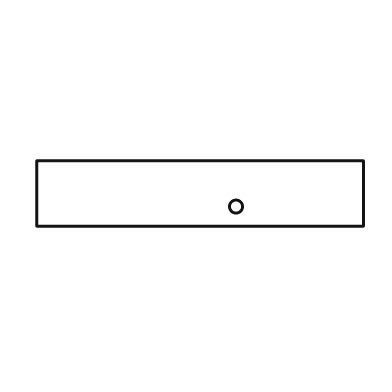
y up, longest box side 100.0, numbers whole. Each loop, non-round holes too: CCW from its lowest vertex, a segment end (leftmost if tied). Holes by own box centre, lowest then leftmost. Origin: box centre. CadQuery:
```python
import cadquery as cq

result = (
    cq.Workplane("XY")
    .moveTo(-50.0, -10.0)
    .lineTo(50.0, -10.0)
    .lineTo(50.0, 10.0)
    .lineTo(-50.0, 10.0)
    .close()
    .moveTo(11.0, -4.0)
    .circle(2.0)
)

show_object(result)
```